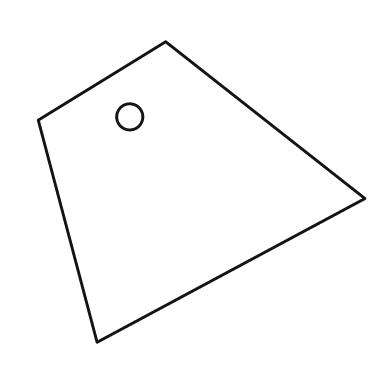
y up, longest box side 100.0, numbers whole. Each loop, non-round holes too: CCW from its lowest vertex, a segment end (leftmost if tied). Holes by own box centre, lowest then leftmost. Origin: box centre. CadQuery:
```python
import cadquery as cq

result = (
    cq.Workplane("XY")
    .moveTo(-32.0, -46.0)
    .lineTo(50.0, -2.0)
    .lineTo(-11.0, 46.0)
    .lineTo(-50.0, 22.0)
    .close()
    .moveTo(-22.0, 23.0)
    .circle(4.0)
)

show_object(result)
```